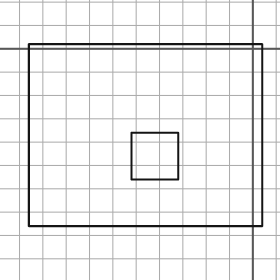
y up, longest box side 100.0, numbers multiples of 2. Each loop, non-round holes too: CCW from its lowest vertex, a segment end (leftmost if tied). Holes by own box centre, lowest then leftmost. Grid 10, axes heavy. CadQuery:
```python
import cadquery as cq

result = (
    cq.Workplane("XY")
    .moveTo(-96.0, -76.0)
    .lineTo(4.0, -76.0)
    .lineTo(4.0, 2.0)
    .lineTo(-96.0, 2.0)
    .close()
    .moveTo(-52.0, -56.0)
    .lineTo(-32.0, -56.0)
    .lineTo(-32.0, -36.0)
    .lineTo(-52.0, -36.0)
    .close()
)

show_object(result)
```